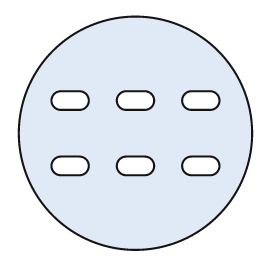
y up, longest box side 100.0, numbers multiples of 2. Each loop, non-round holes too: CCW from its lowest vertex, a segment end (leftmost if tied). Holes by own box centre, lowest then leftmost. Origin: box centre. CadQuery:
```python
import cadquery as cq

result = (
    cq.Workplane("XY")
    .moveTo(0.0, 0.0)
    .circle(50.0)
    .moveTo(-32.0, -18.0)
    .lineTo(-24.0, -18.0)
    .threePointArc((-20.0, -14.0), (-24.0, -10.0))
    .lineTo(-32.0, -10.0)
    .threePointArc((-36.0, -14.0), (-32.0, -18.0))
    .close()
    .moveTo(-4.0, -18.0)
    .lineTo(4.0, -18.0)
    .threePointArc((8.0, -14.0), (4.0, -10.0))
    .lineTo(-4.0, -10.0)
    .threePointArc((-8.0, -14.0), (-4.0, -18.0))
    .close()
    .moveTo(24.0, -18.0)
    .lineTo(32.0, -18.0)
    .threePointArc((36.0, -14.0), (32.0, -10.0))
    .lineTo(24.0, -10.0)
    .threePointArc((20.0, -14.0), (24.0, -18.0))
    .close()
    .moveTo(-32.0, 10.0)
    .lineTo(-24.0, 10.0)
    .threePointArc((-20.0, 14.0), (-24.0, 18.0))
    .lineTo(-32.0, 18.0)
    .threePointArc((-36.0, 14.0), (-32.0, 10.0))
    .close()
    .moveTo(-4.0, 10.0)
    .lineTo(4.0, 10.0)
    .threePointArc((8.0, 14.0), (4.0, 18.0))
    .lineTo(-4.0, 18.0)
    .threePointArc((-8.0, 14.0), (-4.0, 10.0))
    .close()
    .moveTo(24.0, 10.0)
    .lineTo(32.0, 10.0)
    .threePointArc((36.0, 14.0), (32.0, 18.0))
    .lineTo(24.0, 18.0)
    .threePointArc((20.0, 14.0), (24.0, 10.0))
    .close()
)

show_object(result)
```